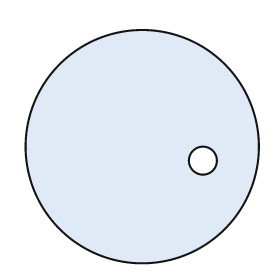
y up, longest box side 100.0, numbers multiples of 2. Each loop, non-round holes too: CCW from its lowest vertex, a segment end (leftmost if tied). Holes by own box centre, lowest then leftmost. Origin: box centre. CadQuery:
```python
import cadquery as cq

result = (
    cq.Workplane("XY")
    .moveTo(0.0, 0.0)
    .circle(50.0)
    .moveTo(26.0, -6.0)
    .circle(6.0)
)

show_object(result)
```